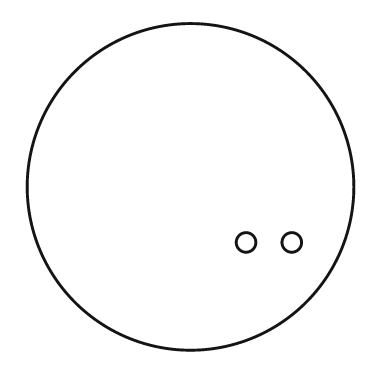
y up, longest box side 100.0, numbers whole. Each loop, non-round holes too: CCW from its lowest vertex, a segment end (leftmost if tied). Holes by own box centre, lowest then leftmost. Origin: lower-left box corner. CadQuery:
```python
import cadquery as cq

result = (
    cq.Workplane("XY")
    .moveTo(50.0, 50.0)
    .circle(50.0)
    .moveTo(67.0, 33.0)
    .circle(3.0)
    .moveTo(81.0, 33.0)
    .circle(3.0)
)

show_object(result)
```